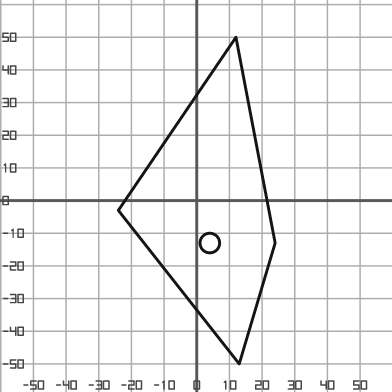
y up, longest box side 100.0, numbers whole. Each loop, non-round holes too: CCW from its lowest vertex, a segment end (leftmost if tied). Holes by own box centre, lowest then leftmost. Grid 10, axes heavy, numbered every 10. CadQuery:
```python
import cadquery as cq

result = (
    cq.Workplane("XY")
    .moveTo(13.0, -50.0)
    .lineTo(24.0, -13.0)
    .lineTo(12.0, 50.0)
    .lineTo(-24.0, -3.0)
    .close()
    .moveTo(4.0, -13.0)
    .circle(3.0)
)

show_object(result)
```